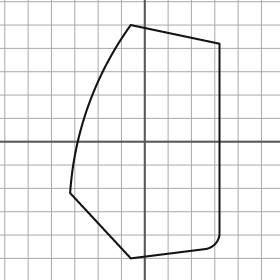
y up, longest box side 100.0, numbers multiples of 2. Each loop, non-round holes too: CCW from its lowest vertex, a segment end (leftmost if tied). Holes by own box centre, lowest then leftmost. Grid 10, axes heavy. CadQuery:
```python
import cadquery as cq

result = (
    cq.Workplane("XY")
    .moveTo(-6.0, -50.0)
    .lineTo(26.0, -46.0)
    .threePointArc((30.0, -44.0), (32.0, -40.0))
    .lineTo(32.0, 42.0)
    .lineTo(-6.0, 50.0)
    .threePointArc((-24.0, 16.0), (-32.0, -22.0))
    .close()
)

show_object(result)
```